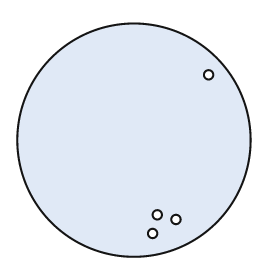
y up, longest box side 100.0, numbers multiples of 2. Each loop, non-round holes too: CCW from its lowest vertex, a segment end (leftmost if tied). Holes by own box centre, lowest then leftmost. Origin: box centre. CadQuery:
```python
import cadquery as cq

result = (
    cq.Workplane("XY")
    .moveTo(0.0, 0.0)
    .circle(50.0)
    .moveTo(8.0, -40.0)
    .circle(2.0)
    .moveTo(18.0, -34.0)
    .circle(2.0)
    .moveTo(10.0, -32.0)
    .circle(2.0)
    .moveTo(32.0, 28.0)
    .circle(2.0)
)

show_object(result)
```